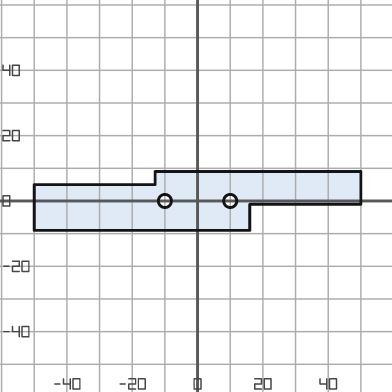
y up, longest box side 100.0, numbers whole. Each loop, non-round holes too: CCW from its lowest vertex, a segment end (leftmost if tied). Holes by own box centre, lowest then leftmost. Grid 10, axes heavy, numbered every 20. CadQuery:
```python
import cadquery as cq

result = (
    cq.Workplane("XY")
    .moveTo(-50.0, -9.0)
    .lineTo(16.0, -9.0)
    .lineTo(16.0, -1.0)
    .lineTo(50.0, -1.0)
    .lineTo(50.0, 9.0)
    .lineTo(-13.0, 9.0)
    .lineTo(-13.0, 5.0)
    .lineTo(-50.0, 5.0)
    .close()
    .moveTo(-10.0, 0.0)
    .circle(2.0)
    .moveTo(10.0, 0.0)
    .circle(2.0)
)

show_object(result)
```